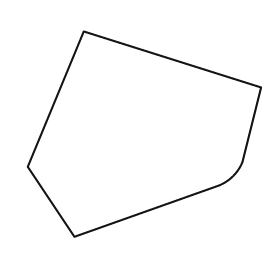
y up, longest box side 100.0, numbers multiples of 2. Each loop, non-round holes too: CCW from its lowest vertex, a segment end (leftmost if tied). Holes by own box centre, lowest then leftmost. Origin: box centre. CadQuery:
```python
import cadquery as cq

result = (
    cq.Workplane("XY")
    .moveTo(-30.0, -44.0)
    .lineTo(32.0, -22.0)
    .threePointArc((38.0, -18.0), (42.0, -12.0))
    .lineTo(50.0, 20.0)
    .lineTo(-26.0, 44.0)
    .lineTo(-50.0, -14.0)
    .close()
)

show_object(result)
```